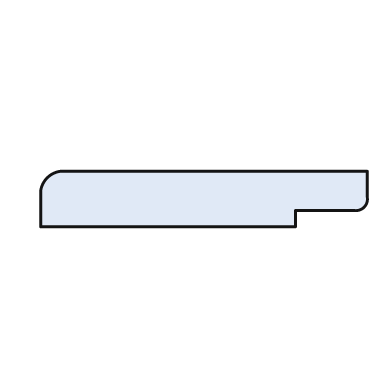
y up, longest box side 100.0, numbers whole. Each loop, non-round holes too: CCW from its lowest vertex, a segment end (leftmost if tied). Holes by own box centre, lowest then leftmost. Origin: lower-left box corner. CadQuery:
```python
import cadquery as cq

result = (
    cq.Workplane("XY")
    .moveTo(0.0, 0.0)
    .lineTo(78.0, 0.0)
    .lineTo(78.0, 5.0)
    .lineTo(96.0, 5.0)
    .threePointArc((99.0, 6.0), (100.0, 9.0))
    .lineTo(100.0, 17.0)
    .lineTo(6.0, 17.0)
    .threePointArc((2.0, 15.0), (0.0, 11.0))
    .close()
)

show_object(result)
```